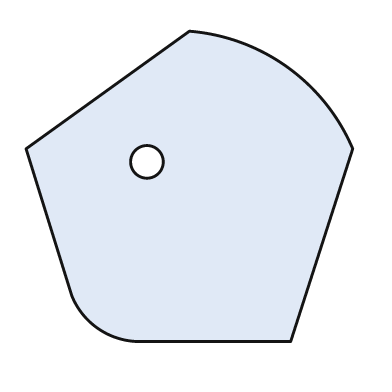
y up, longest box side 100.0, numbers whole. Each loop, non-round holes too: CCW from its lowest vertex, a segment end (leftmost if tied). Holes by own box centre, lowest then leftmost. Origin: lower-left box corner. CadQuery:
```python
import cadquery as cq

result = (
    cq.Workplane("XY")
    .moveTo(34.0, 0.0)
    .lineTo(81.0, 0.0)
    .lineTo(100.0, 59.0)
    .threePointArc((80.0, 84.0), (50.0, 95.0))
    .lineTo(0.0, 59.0)
    .lineTo(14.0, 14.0)
    .threePointArc((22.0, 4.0), (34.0, 0.0))
    .close()
    .moveTo(37.0, 55.0)
    .circle(5.0)
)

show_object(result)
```